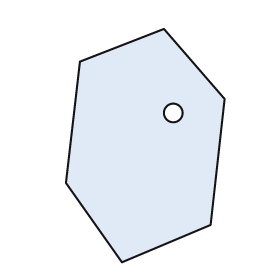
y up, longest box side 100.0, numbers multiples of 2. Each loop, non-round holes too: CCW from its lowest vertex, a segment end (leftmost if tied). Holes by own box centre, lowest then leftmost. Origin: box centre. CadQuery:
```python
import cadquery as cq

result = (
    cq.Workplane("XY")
    .moveTo(-10.0, -50.0)
    .lineTo(28.0, -34.0)
    .lineTo(34.0, 20.0)
    .lineTo(8.0, 50.0)
    .lineTo(-28.0, 36.0)
    .lineTo(-34.0, -16.0)
    .close()
    .moveTo(12.0, 14.0)
    .circle(4.0)
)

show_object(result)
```